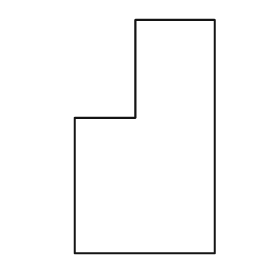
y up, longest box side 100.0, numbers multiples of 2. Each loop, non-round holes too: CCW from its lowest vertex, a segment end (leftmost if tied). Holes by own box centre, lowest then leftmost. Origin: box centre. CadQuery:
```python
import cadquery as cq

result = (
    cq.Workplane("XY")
    .moveTo(-30.0, -50.0)
    .lineTo(30.0, -50.0)
    .lineTo(30.0, 50.0)
    .lineTo(-4.0, 50.0)
    .lineTo(-4.0, 8.0)
    .lineTo(-30.0, 8.0)
    .close()
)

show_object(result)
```